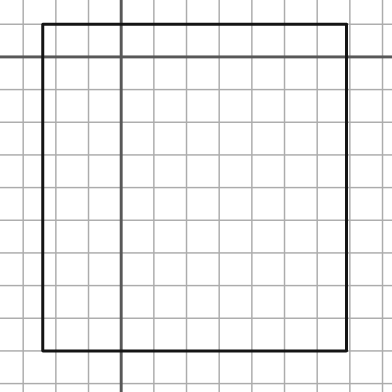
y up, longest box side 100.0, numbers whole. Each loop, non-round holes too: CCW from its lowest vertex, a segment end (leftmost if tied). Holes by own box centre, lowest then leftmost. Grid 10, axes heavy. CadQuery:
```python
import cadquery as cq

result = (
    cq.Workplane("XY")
    .moveTo(-24.0, -90.0)
    .lineTo(69.0, -90.0)
    .lineTo(69.0, 10.0)
    .lineTo(-24.0, 10.0)
    .close()
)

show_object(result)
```